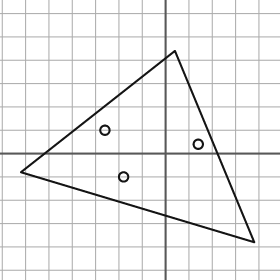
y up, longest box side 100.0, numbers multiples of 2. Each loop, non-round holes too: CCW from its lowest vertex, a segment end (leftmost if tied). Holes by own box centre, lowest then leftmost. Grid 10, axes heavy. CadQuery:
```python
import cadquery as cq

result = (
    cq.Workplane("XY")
    .moveTo(38.0, -38.0)
    .lineTo(4.0, 44.0)
    .lineTo(-62.0, -8.0)
    .close()
    .moveTo(-18.0, -10.0)
    .circle(2.0)
    .moveTo(14.0, 4.0)
    .circle(2.0)
    .moveTo(-26.0, 10.0)
    .circle(2.0)
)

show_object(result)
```